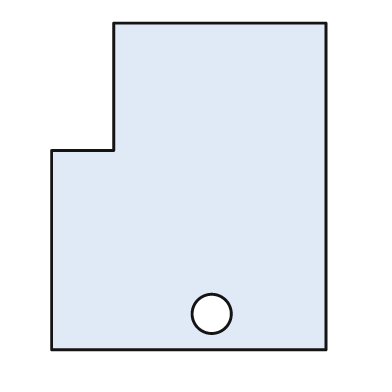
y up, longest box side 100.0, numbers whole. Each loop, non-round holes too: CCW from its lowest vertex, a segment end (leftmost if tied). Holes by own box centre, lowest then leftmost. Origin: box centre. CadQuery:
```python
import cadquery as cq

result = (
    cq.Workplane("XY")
    .moveTo(-42.0, -50.0)
    .lineTo(42.0, -50.0)
    .lineTo(42.0, 50.0)
    .lineTo(-23.0, 50.0)
    .lineTo(-23.0, 11.0)
    .lineTo(-42.0, 11.0)
    .close()
    .moveTo(7.0, -39.0)
    .circle(6.0)
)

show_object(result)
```